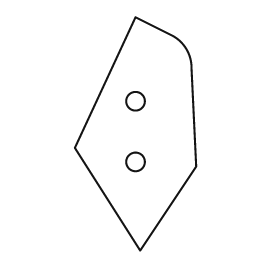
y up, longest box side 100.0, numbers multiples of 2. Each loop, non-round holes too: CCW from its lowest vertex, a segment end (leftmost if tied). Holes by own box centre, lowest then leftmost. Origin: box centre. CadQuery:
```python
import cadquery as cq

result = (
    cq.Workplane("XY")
    .moveTo(2.0, -50.0)
    .lineTo(26.0, -14.0)
    .lineTo(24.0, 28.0)
    .threePointArc((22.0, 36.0), (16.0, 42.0))
    .lineTo(0.0, 50.0)
    .lineTo(-26.0, -6.0)
    .close()
    .moveTo(0.0, -12.0)
    .circle(4.0)
    .moveTo(0.0, 14.0)
    .circle(4.0)
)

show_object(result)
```